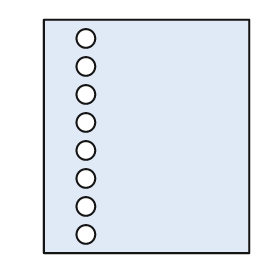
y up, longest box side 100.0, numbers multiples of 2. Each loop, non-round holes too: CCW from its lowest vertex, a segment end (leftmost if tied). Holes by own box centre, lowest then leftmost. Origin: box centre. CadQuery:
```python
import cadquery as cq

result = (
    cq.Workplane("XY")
    .moveTo(-44.0, -50.0)
    .lineTo(44.0, -50.0)
    .lineTo(44.0, 50.0)
    .lineTo(-44.0, 50.0)
    .close()
    .moveTo(-26.0, -42.0)
    .circle(4.0)
    .moveTo(-26.0, -30.0)
    .circle(4.0)
    .moveTo(-26.0, -18.0)
    .circle(4.0)
    .moveTo(-26.0, -6.0)
    .circle(4.0)
    .moveTo(-26.0, 6.0)
    .circle(4.0)
    .moveTo(-26.0, 18.0)
    .circle(4.0)
    .moveTo(-26.0, 30.0)
    .circle(4.0)
    .moveTo(-26.0, 42.0)
    .circle(4.0)
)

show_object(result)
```